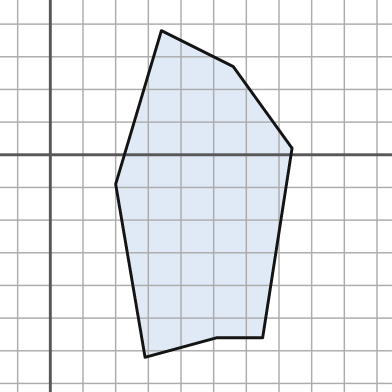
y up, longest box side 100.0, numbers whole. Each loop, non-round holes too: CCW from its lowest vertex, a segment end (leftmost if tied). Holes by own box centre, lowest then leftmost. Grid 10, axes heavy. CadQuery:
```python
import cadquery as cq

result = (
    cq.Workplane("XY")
    .moveTo(29.0, -62.0)
    .lineTo(51.0, -56.0)
    .lineTo(65.0, -56.0)
    .lineTo(74.0, 2.0)
    .lineTo(56.0, 27.0)
    .lineTo(34.0, 38.0)
    .lineTo(20.0, -9.0)
    .close()
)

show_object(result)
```